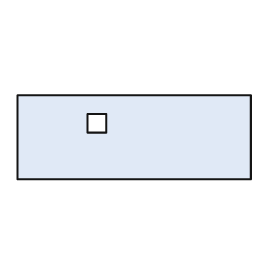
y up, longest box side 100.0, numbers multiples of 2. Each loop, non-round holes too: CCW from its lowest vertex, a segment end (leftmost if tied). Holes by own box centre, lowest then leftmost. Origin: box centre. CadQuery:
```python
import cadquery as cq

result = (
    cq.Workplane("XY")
    .moveTo(-50.0, -18.0)
    .lineTo(50.0, -18.0)
    .lineTo(50.0, 18.0)
    .lineTo(-50.0, 18.0)
    .close()
    .moveTo(-20.0, 2.0)
    .lineTo(-12.0, 2.0)
    .lineTo(-12.0, 10.0)
    .lineTo(-20.0, 10.0)
    .close()
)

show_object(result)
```